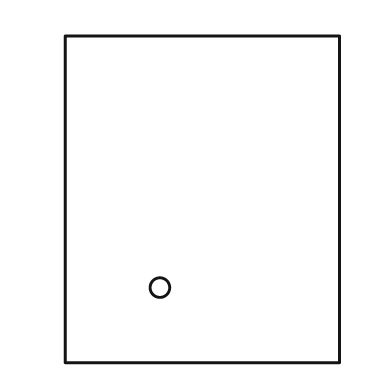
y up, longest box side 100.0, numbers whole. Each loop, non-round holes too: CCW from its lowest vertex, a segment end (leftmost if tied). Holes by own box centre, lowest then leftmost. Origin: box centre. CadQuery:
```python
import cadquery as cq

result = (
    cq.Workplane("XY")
    .moveTo(-42.0, -50.0)
    .lineTo(42.0, -50.0)
    .lineTo(42.0, 50.0)
    .lineTo(-42.0, 50.0)
    .close()
    .moveTo(-13.0, -27.0)
    .circle(3.0)
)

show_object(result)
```